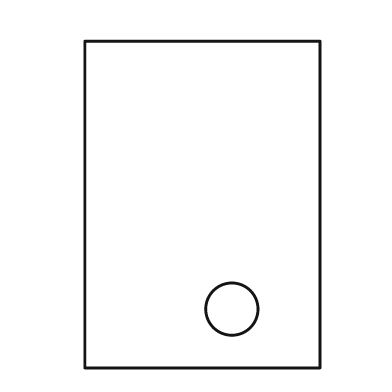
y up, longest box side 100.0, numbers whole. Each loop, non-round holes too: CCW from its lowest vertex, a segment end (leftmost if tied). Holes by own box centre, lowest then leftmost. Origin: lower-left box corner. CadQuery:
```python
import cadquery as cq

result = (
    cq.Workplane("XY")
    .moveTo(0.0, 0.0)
    .lineTo(72.0, 0.0)
    .lineTo(72.0, 100.0)
    .lineTo(0.0, 100.0)
    .close()
    .moveTo(45.0, 18.0)
    .circle(8.0)
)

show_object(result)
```